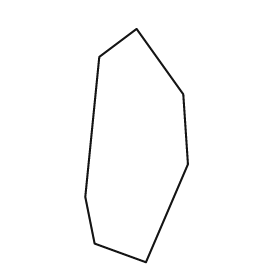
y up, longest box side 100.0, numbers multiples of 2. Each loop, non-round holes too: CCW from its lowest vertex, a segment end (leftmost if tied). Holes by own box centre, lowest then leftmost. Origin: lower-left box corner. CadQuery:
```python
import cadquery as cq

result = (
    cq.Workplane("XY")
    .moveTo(26.0, 0.0)
    .lineTo(44.0, 42.0)
    .lineTo(42.0, 72.0)
    .lineTo(22.0, 100.0)
    .lineTo(6.0, 88.0)
    .lineTo(0.0, 28.0)
    .lineTo(4.0, 8.0)
    .close()
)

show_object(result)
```